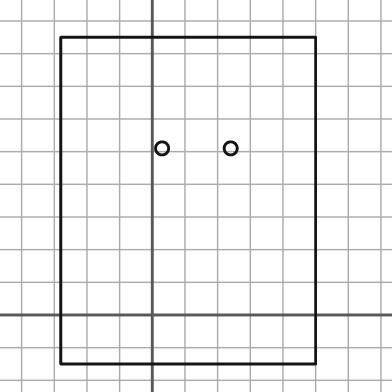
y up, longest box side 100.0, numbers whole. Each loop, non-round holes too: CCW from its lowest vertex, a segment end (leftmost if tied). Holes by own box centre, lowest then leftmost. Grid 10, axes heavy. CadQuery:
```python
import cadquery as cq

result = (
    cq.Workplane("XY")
    .moveTo(-28.0, -15.0)
    .lineTo(50.0, -15.0)
    .lineTo(50.0, 85.0)
    .lineTo(-28.0, 85.0)
    .close()
    .moveTo(3.0, 51.0)
    .circle(2.0)
    .moveTo(24.0, 51.0)
    .circle(2.0)
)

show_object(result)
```